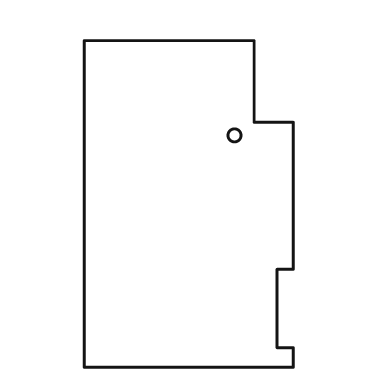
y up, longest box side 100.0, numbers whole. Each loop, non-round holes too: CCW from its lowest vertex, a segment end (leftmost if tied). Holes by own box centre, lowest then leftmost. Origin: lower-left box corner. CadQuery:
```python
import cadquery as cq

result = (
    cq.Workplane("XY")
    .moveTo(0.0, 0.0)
    .lineTo(64.0, 0.0)
    .lineTo(64.0, 6.0)
    .lineTo(59.0, 6.0)
    .lineTo(59.0, 30.0)
    .lineTo(64.0, 30.0)
    .lineTo(64.0, 75.0)
    .lineTo(52.0, 75.0)
    .lineTo(52.0, 100.0)
    .lineTo(0.0, 100.0)
    .close()
    .moveTo(46.0, 71.0)
    .circle(2.0)
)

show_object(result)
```